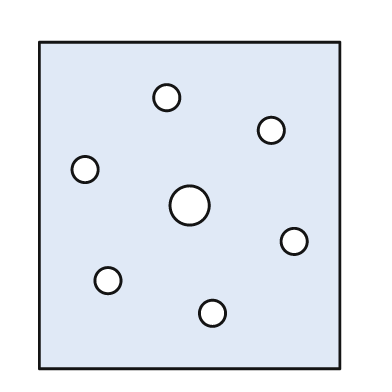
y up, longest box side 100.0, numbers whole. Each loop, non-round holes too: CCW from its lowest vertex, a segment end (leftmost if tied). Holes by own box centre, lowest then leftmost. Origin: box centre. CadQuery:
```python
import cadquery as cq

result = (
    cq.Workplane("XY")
    .moveTo(-46.0, -50.0)
    .lineTo(46.0, -50.0)
    .lineTo(46.0, 50.0)
    .lineTo(-46.0, 50.0)
    .close()
    .moveTo(7.0, -33.0)
    .circle(4.0)
    .moveTo(-25.0, -23.0)
    .circle(4.0)
    .moveTo(32.0, -11.0)
    .circle(4.0)
    .moveTo(0.0, 0.0)
    .circle(6.0)
    .moveTo(-32.0, 11.0)
    .circle(4.0)
    .moveTo(25.0, 23.0)
    .circle(4.0)
    .moveTo(-7.0, 33.0)
    .circle(4.0)
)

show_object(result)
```